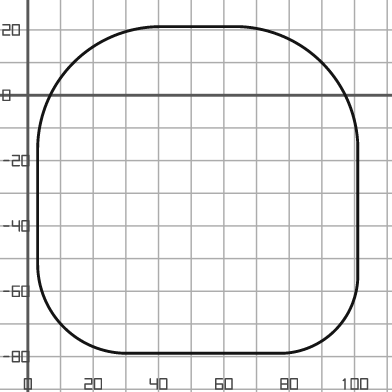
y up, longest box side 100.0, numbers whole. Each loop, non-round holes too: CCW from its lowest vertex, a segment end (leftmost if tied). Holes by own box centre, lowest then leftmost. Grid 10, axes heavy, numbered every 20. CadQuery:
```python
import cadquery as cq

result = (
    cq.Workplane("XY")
    .moveTo(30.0, -79.0)
    .lineTo(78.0, -79.0)
    .threePointArc((94.0, -72.0), (101.0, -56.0))
    .lineTo(101.0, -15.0)
    .threePointArc((90.0, 10.0), (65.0, 21.0))
    .lineTo(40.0, 21.0)
    .threePointArc((14.0, 10.0), (3.0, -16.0))
    .lineTo(3.0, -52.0)
    .threePointArc((11.0, -71.0), (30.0, -79.0))
    .close()
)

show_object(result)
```